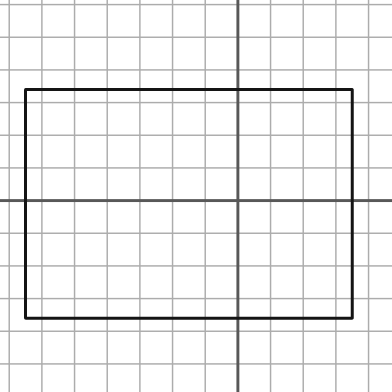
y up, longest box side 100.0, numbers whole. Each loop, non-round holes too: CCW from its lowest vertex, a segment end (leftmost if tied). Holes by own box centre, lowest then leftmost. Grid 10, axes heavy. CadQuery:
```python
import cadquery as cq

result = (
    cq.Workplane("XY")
    .moveTo(-65.0, -36.0)
    .lineTo(35.0, -36.0)
    .lineTo(35.0, 34.0)
    .lineTo(-65.0, 34.0)
    .close()
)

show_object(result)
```